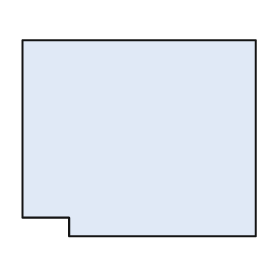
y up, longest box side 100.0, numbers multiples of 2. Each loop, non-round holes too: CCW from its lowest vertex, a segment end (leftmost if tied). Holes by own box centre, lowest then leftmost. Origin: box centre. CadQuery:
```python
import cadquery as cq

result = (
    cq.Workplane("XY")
    .moveTo(-30.0, -42.0)
    .lineTo(50.0, -42.0)
    .lineTo(50.0, 42.0)
    .lineTo(-50.0, 42.0)
    .lineTo(-50.0, -34.0)
    .lineTo(-30.0, -34.0)
    .close()
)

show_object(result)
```